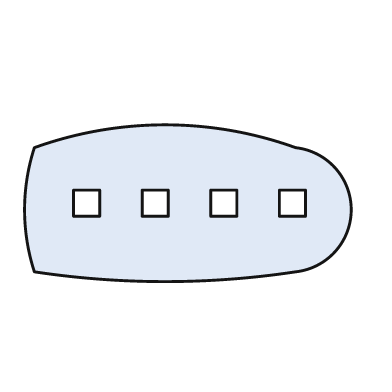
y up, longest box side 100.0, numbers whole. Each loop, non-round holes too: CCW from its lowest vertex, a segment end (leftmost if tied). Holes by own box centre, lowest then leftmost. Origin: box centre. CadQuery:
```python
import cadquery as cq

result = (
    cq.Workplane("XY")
    .moveTo(-47.0, -21.0)
    .threePointArc((-7.0, -24.0), (33.0, -21.0))
    .threePointArc((50.0, -2.0), (33.0, 17.0))
    .threePointArc((-7.0, 24.0), (-47.0, 17.0))
    .threePointArc((-50.0, -2.0), (-47.0, -21.0))
    .close()
    .moveTo(-35.0, -4.0)
    .lineTo(-27.0, -4.0)
    .lineTo(-27.0, 4.0)
    .lineTo(-35.0, 4.0)
    .close()
    .moveTo(-14.0, -4.0)
    .lineTo(-6.0, -4.0)
    .lineTo(-6.0, 4.0)
    .lineTo(-14.0, 4.0)
    .close()
    .moveTo(7.0, -4.0)
    .lineTo(15.0, -4.0)
    .lineTo(15.0, 4.0)
    .lineTo(7.0, 4.0)
    .close()
    .moveTo(28.0, -4.0)
    .lineTo(36.0, -4.0)
    .lineTo(36.0, 4.0)
    .lineTo(28.0, 4.0)
    .close()
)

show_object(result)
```